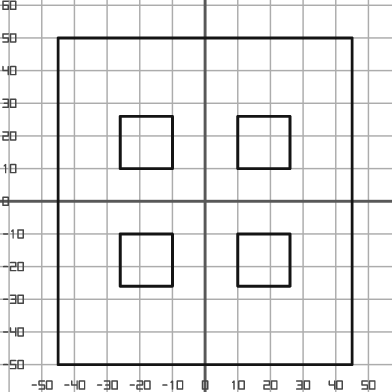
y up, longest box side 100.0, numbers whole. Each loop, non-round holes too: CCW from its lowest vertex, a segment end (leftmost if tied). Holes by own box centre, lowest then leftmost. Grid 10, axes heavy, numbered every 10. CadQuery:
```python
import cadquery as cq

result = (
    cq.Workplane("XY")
    .moveTo(-45.0, -50.0)
    .lineTo(45.0, -50.0)
    .lineTo(45.0, 50.0)
    .lineTo(-45.0, 50.0)
    .close()
    .moveTo(-26.0, -26.0)
    .lineTo(-10.0, -26.0)
    .lineTo(-10.0, -10.0)
    .lineTo(-26.0, -10.0)
    .close()
    .moveTo(10.0, -26.0)
    .lineTo(26.0, -26.0)
    .lineTo(26.0, -10.0)
    .lineTo(10.0, -10.0)
    .close()
    .moveTo(-26.0, 10.0)
    .lineTo(-10.0, 10.0)
    .lineTo(-10.0, 26.0)
    .lineTo(-26.0, 26.0)
    .close()
    .moveTo(10.0, 10.0)
    .lineTo(26.0, 10.0)
    .lineTo(26.0, 26.0)
    .lineTo(10.0, 26.0)
    .close()
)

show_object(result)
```